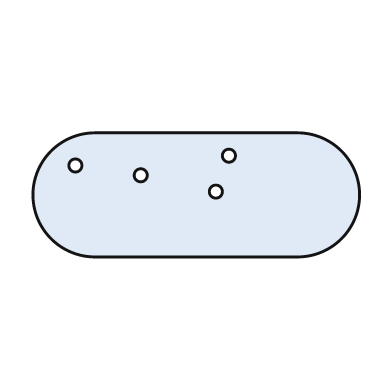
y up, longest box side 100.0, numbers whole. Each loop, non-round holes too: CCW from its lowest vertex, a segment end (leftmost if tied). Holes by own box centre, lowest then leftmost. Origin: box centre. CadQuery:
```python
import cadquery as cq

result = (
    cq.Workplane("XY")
    .moveTo(-31.0, -19.0)
    .lineTo(31.0, -19.0)
    .threePointArc((50.0, 0.0), (31.0, 19.0))
    .lineTo(-31.0, 19.0)
    .threePointArc((-50.0, 0.0), (-31.0, -19.0))
    .close()
    .moveTo(6.0, 1.0)
    .circle(2.0)
    .moveTo(-17.0, 6.0)
    .circle(2.0)
    .moveTo(-37.0, 9.0)
    .circle(2.0)
    .moveTo(10.0, 12.0)
    .circle(2.0)
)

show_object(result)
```